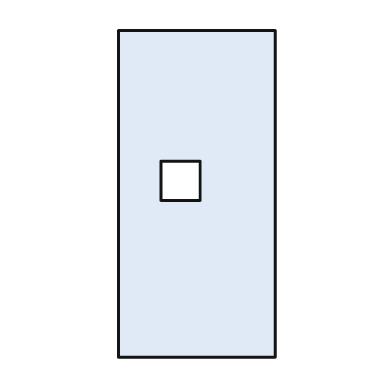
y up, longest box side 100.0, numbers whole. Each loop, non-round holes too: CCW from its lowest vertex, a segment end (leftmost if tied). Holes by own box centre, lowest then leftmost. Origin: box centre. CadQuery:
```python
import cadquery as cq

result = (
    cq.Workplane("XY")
    .moveTo(-24.0, -50.0)
    .lineTo(24.0, -50.0)
    .lineTo(24.0, 50.0)
    .lineTo(-24.0, 50.0)
    .close()
    .moveTo(-11.0, -2.0)
    .lineTo(1.0, -2.0)
    .lineTo(1.0, 10.0)
    .lineTo(-11.0, 10.0)
    .close()
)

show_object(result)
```